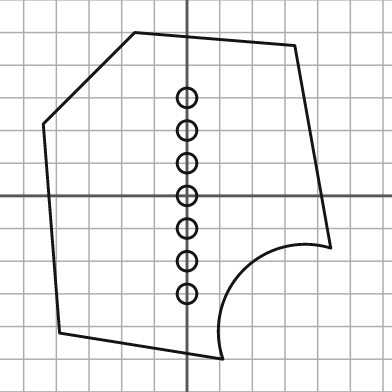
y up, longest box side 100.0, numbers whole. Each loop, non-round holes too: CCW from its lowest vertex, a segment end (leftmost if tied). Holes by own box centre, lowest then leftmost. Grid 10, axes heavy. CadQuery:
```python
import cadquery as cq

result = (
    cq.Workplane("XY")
    .moveTo(11.0, -50.0)
    .threePointArc((17.0, -23.0), (44.0, -16.0))
    .lineTo(33.0, 46.0)
    .lineTo(-16.0, 50.0)
    .lineTo(-44.0, 22.0)
    .lineTo(-39.0, -42.0)
    .close()
    .moveTo(0.0, -30.0)
    .circle(3.0)
    .moveTo(0.0, -20.0)
    .circle(3.0)
    .moveTo(0.0, -10.0)
    .circle(3.0)
    .moveTo(0.0, 0.0)
    .circle(3.0)
    .moveTo(0.0, 10.0)
    .circle(3.0)
    .moveTo(0.0, 20.0)
    .circle(3.0)
    .moveTo(0.0, 30.0)
    .circle(3.0)
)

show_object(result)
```